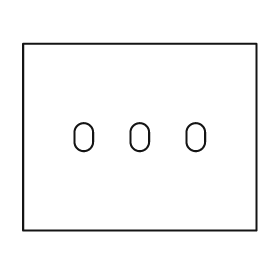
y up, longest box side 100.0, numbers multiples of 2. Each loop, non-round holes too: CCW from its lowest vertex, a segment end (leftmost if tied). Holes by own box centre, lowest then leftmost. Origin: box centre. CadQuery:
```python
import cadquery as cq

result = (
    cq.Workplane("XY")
    .moveTo(-50.0, -40.0)
    .lineTo(50.0, -40.0)
    .lineTo(50.0, 40.0)
    .lineTo(-50.0, 40.0)
    .close()
    .moveTo(-28.0, -2.0)
    .threePointArc((-24.0, -6.0), (-20.0, -2.0))
    .lineTo(-20.0, 2.0)
    .threePointArc((-24.0, 6.0), (-28.0, 2.0))
    .close()
    .moveTo(-4.0, -2.0)
    .threePointArc((0.0, -6.0), (4.0, -2.0))
    .lineTo(4.0, 2.0)
    .threePointArc((0.0, 6.0), (-4.0, 2.0))
    .close()
    .moveTo(20.0, -2.0)
    .threePointArc((24.0, -6.0), (28.0, -2.0))
    .lineTo(28.0, 2.0)
    .threePointArc((24.0, 6.0), (20.0, 2.0))
    .close()
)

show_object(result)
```